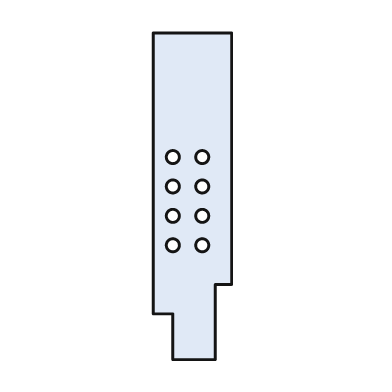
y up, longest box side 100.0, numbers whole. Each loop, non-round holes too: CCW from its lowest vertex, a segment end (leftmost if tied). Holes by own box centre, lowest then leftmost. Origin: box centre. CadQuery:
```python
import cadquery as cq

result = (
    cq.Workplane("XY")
    .moveTo(-6.0, -50.0)
    .lineTo(7.0, -50.0)
    .lineTo(7.0, -27.0)
    .lineTo(12.0, -27.0)
    .lineTo(12.0, 50.0)
    .lineTo(-12.0, 50.0)
    .lineTo(-12.0, -36.0)
    .lineTo(-6.0, -36.0)
    .close()
    .moveTo(-6.0, -15.0)
    .circle(2.0)
    .moveTo(3.0, -15.0)
    .circle(2.0)
    .moveTo(-6.0, -6.0)
    .circle(2.0)
    .moveTo(3.0, -6.0)
    .circle(2.0)
    .moveTo(-6.0, 3.0)
    .circle(2.0)
    .moveTo(3.0, 3.0)
    .circle(2.0)
    .moveTo(-6.0, 12.0)
    .circle(2.0)
    .moveTo(3.0, 12.0)
    .circle(2.0)
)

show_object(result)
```